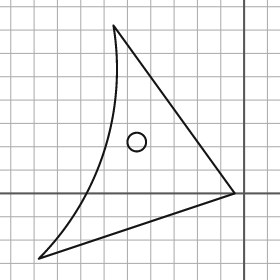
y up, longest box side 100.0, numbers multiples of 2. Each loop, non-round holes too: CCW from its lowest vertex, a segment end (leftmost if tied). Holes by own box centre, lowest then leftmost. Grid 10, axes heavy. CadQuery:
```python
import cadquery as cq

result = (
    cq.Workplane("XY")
    .moveTo(-88.0, -28.0)
    .lineTo(-4.0, 0.0)
    .lineTo(-56.0, 72.0)
    .threePointArc((-60.0, 18.0), (-88.0, -28.0))
    .close()
    .moveTo(-46.0, 22.0)
    .circle(4.0)
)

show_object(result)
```